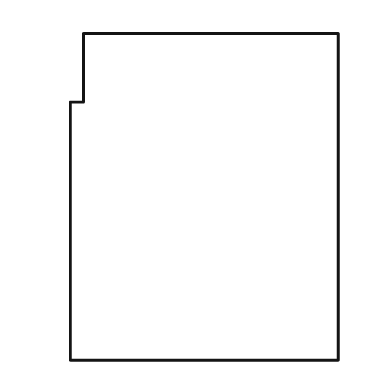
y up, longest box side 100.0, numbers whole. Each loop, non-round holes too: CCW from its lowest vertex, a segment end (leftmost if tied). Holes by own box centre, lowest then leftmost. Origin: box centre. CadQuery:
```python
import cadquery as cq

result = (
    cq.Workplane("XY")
    .moveTo(-41.0, -50.0)
    .lineTo(41.0, -50.0)
    .lineTo(41.0, 50.0)
    .lineTo(-37.0, 50.0)
    .lineTo(-37.0, 29.0)
    .lineTo(-41.0, 29.0)
    .close()
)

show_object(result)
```